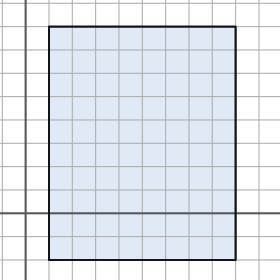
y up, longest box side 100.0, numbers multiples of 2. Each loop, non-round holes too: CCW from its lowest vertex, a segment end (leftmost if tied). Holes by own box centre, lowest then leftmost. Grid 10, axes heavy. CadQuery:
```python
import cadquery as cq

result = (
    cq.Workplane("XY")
    .moveTo(10.0, -20.0)
    .lineTo(90.0, -20.0)
    .lineTo(90.0, 80.0)
    .lineTo(10.0, 80.0)
    .close()
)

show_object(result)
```